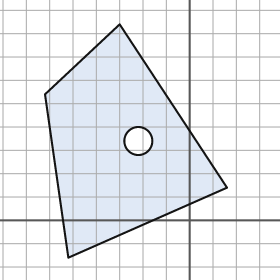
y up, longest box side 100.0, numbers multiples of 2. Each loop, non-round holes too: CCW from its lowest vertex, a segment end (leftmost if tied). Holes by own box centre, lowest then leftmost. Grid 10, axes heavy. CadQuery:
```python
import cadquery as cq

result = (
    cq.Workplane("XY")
    .moveTo(-52.0, -16.0)
    .lineTo(16.0, 14.0)
    .lineTo(-30.0, 84.0)
    .lineTo(-62.0, 54.0)
    .close()
    .moveTo(-22.0, 34.0)
    .circle(6.0)
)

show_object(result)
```